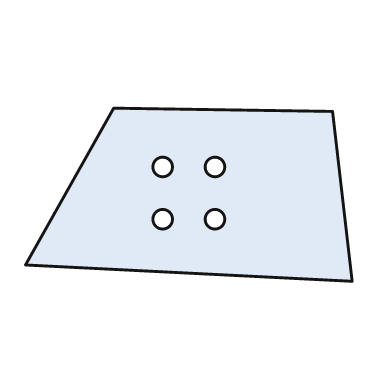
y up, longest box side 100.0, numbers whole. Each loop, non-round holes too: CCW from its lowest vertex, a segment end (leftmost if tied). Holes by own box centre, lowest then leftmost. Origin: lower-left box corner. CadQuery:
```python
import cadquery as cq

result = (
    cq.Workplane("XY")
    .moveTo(100.0, 0.0)
    .lineTo(94.0, 52.0)
    .lineTo(27.0, 53.0)
    .lineTo(0.0, 5.0)
    .close()
    .moveTo(42.0, 19.0)
    .circle(3.0)
    .moveTo(58.0, 19.0)
    .circle(3.0)
    .moveTo(42.0, 35.0)
    .circle(3.0)
    .moveTo(58.0, 35.0)
    .circle(3.0)
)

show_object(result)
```